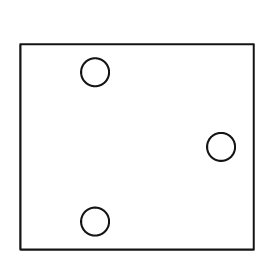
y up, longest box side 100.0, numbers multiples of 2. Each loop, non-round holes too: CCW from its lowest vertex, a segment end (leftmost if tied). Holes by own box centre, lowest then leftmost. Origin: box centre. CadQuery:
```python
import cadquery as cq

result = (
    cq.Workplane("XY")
    .moveTo(-50.0, -44.0)
    .lineTo(50.0, -44.0)
    .lineTo(50.0, 44.0)
    .lineTo(-50.0, 44.0)
    .close()
    .moveTo(-18.0, -32.0)
    .circle(6.0)
    .moveTo(36.0, 0.0)
    .circle(6.0)
    .moveTo(-18.0, 32.0)
    .circle(6.0)
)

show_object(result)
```